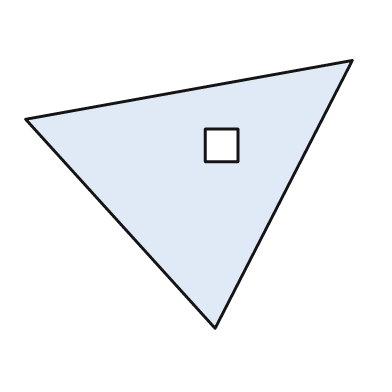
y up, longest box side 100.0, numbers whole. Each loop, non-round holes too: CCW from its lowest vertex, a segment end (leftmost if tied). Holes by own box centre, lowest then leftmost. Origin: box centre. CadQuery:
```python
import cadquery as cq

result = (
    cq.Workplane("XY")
    .moveTo(8.0, -41.0)
    .lineTo(50.0, 41.0)
    .lineTo(-50.0, 23.0)
    .close()
    .moveTo(5.0, 10.0)
    .lineTo(15.0, 10.0)
    .lineTo(15.0, 20.0)
    .lineTo(5.0, 20.0)
    .close()
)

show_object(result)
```